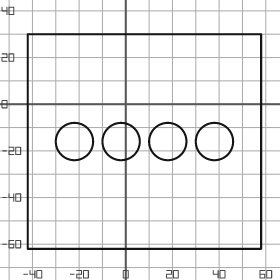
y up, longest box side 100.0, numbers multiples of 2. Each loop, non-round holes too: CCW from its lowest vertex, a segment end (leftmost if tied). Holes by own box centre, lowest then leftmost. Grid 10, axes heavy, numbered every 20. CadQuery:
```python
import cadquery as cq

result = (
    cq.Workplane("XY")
    .moveTo(-42.0, -62.0)
    .lineTo(58.0, -62.0)
    .lineTo(58.0, 30.0)
    .lineTo(-42.0, 30.0)
    .close()
    .moveTo(-22.0, -16.0)
    .circle(8.0)
    .moveTo(-2.0, -16.0)
    .circle(8.0)
    .moveTo(18.0, -16.0)
    .circle(8.0)
    .moveTo(38.0, -16.0)
    .circle(8.0)
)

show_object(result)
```